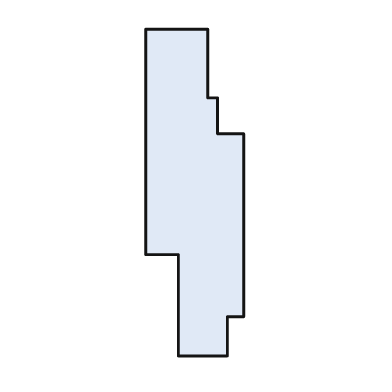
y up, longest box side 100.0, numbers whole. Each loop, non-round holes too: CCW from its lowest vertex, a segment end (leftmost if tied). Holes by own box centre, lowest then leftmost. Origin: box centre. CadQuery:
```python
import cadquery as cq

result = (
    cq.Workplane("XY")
    .moveTo(-5.0, -50.0)
    .lineTo(10.0, -50.0)
    .lineTo(10.0, -38.0)
    .lineTo(15.0, -38.0)
    .lineTo(15.0, 18.0)
    .lineTo(7.0, 18.0)
    .lineTo(7.0, 29.0)
    .lineTo(4.0, 29.0)
    .lineTo(4.0, 50.0)
    .lineTo(-15.0, 50.0)
    .lineTo(-15.0, -19.0)
    .lineTo(-5.0, -19.0)
    .close()
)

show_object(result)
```